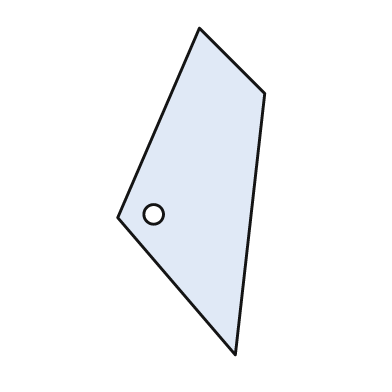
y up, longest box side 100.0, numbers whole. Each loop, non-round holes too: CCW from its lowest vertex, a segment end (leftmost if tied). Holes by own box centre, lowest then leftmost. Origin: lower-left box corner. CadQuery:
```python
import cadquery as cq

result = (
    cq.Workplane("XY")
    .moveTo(36.0, 0.0)
    .lineTo(45.0, 80.0)
    .lineTo(25.0, 100.0)
    .lineTo(0.0, 42.0)
    .close()
    .moveTo(11.0, 43.0)
    .circle(3.0)
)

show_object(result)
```